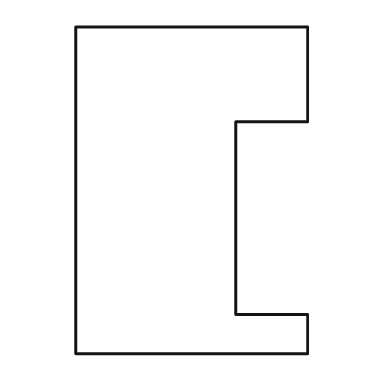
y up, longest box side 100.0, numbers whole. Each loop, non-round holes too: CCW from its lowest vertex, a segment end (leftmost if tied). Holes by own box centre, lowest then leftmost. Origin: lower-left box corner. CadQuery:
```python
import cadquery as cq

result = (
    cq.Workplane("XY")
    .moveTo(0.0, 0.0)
    .lineTo(71.0, 0.0)
    .lineTo(71.0, 12.0)
    .lineTo(49.0, 12.0)
    .lineTo(49.0, 71.0)
    .lineTo(71.0, 71.0)
    .lineTo(71.0, 100.0)
    .lineTo(0.0, 100.0)
    .close()
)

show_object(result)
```